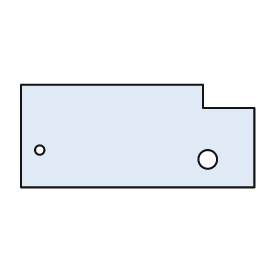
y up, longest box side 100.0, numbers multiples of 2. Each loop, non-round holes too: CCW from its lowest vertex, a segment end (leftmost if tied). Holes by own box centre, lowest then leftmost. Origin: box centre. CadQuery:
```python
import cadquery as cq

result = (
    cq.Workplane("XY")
    .moveTo(-50.0, -22.0)
    .lineTo(50.0, -22.0)
    .lineTo(50.0, 12.0)
    .lineTo(28.0, 12.0)
    .lineTo(28.0, 22.0)
    .lineTo(-50.0, 22.0)
    .close()
    .moveTo(30.0, -10.0)
    .circle(4.0)
    .moveTo(-42.0, -6.0)
    .circle(2.0)
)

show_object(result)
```